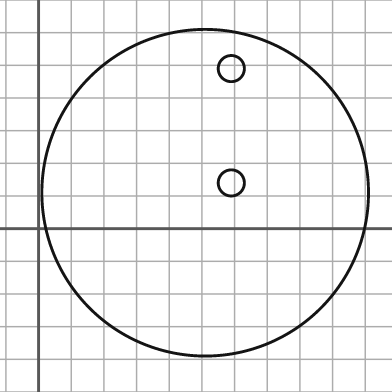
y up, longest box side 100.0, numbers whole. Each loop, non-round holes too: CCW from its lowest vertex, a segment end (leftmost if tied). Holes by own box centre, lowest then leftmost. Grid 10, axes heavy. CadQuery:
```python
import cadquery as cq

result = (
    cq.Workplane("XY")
    .moveTo(51.0, 11.0)
    .circle(50.0)
    .moveTo(59.0, 14.0)
    .circle(4.0)
    .moveTo(59.0, 49.0)
    .circle(4.0)
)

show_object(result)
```